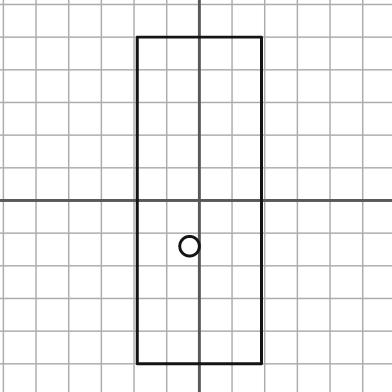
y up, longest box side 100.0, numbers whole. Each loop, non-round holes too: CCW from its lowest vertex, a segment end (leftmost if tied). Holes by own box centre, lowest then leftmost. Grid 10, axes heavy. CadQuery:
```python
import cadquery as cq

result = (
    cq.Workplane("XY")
    .moveTo(-19.0, -50.0)
    .lineTo(19.0, -50.0)
    .lineTo(19.0, 50.0)
    .lineTo(-19.0, 50.0)
    .close()
    .moveTo(-3.0, -14.0)
    .circle(3.0)
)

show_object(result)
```